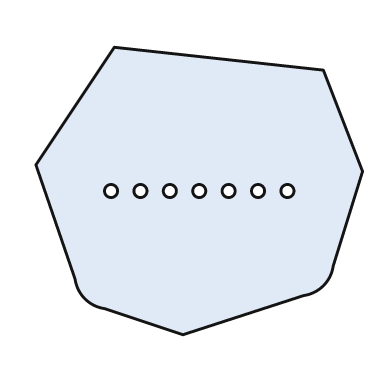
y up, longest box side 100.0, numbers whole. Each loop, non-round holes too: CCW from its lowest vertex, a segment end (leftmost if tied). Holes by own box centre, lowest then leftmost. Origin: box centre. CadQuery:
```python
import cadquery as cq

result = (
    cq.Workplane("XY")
    .moveTo(-5.0, -44.0)
    .lineTo(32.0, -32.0)
    .threePointArc((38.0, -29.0), (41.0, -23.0))
    .lineTo(50.0, 6.0)
    .lineTo(38.0, 37.0)
    .lineTo(-26.0, 44.0)
    .lineTo(-50.0, 8.0)
    .lineTo(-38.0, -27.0)
    .threePointArc((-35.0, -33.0), (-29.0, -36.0))
    .close()
    .moveTo(-27.0, 0.0)
    .circle(2.0)
    .moveTo(-18.0, 0.0)
    .circle(2.0)
    .moveTo(-9.0, 0.0)
    .circle(2.0)
    .moveTo(0.0, 0.0)
    .circle(2.0)
    .moveTo(9.0, 0.0)
    .circle(2.0)
    .moveTo(18.0, 0.0)
    .circle(2.0)
    .moveTo(27.0, 0.0)
    .circle(2.0)
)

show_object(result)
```